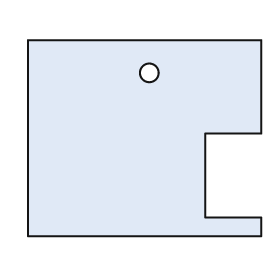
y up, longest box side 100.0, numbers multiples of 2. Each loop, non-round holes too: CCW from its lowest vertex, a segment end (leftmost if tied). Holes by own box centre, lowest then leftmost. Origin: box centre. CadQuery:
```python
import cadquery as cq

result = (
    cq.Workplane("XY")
    .moveTo(-50.0, -42.0)
    .lineTo(50.0, -42.0)
    .lineTo(50.0, -34.0)
    .lineTo(26.0, -34.0)
    .lineTo(26.0, 2.0)
    .lineTo(50.0, 2.0)
    .lineTo(50.0, 42.0)
    .lineTo(-50.0, 42.0)
    .close()
    .moveTo(2.0, 28.0)
    .circle(4.0)
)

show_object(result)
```